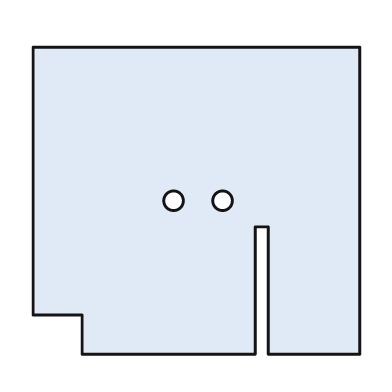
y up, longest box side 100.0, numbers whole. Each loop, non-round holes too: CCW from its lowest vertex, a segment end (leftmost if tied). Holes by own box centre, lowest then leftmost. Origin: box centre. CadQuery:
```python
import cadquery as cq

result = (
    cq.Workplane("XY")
    .moveTo(-35.0, -47.0)
    .lineTo(18.0, -47.0)
    .lineTo(18.0, -8.0)
    .lineTo(22.0, -8.0)
    .lineTo(22.0, -47.0)
    .lineTo(50.0, -47.0)
    .lineTo(50.0, 47.0)
    .lineTo(-50.0, 47.0)
    .lineTo(-50.0, -35.0)
    .lineTo(-35.0, -35.0)
    .close()
    .moveTo(-7.0, 0.0)
    .circle(3.0)
    .moveTo(8.0, 0.0)
    .circle(3.0)
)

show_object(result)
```